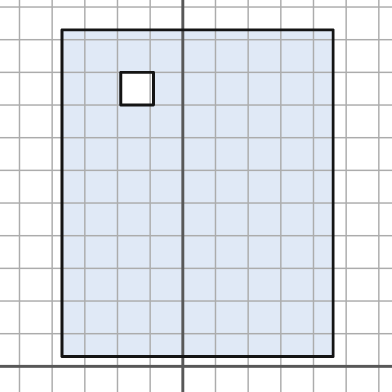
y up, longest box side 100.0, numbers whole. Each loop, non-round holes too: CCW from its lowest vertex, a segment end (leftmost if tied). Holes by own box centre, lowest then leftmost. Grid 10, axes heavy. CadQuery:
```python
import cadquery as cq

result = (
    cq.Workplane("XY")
    .moveTo(-37.0, 3.0)
    .lineTo(46.0, 3.0)
    .lineTo(46.0, 103.0)
    .lineTo(-37.0, 103.0)
    .close()
    .moveTo(-19.0, 80.0)
    .lineTo(-9.0, 80.0)
    .lineTo(-9.0, 90.0)
    .lineTo(-19.0, 90.0)
    .close()
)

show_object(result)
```